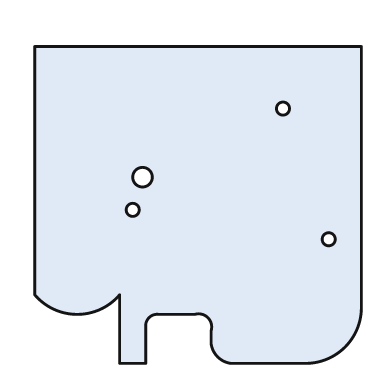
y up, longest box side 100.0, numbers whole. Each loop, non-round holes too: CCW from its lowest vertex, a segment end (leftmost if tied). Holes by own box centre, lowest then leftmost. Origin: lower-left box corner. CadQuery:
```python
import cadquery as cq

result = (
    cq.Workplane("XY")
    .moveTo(26.0, 0.0)
    .lineTo(34.0, 0.0)
    .lineTo(34.0, 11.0)
    .threePointArc((35.0, 14.0), (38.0, 15.0))
    .lineTo(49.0, 15.0)
    .threePointArc((53.0, 14.0), (54.0, 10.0))
    .lineTo(54.0, 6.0)
    .threePointArc((56.0, 2.0), (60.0, 0.0))
    .lineTo(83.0, 0.0)
    .threePointArc((95.0, 5.0), (100.0, 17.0))
    .lineTo(100.0, 97.0)
    .lineTo(0.0, 97.0)
    .lineTo(0.0, 21.0)
    .threePointArc((13.0, 15.0), (26.0, 21.0))
    .close()
    .moveTo(90.0, 38.0)
    .circle(2.0)
    .moveTo(30.0, 47.0)
    .circle(2.0)
    .moveTo(33.0, 57.0)
    .circle(3.0)
    .moveTo(76.0, 78.0)
    .circle(2.0)
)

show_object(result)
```